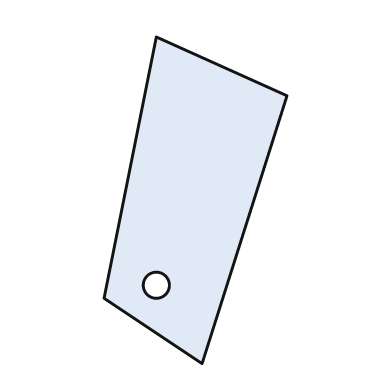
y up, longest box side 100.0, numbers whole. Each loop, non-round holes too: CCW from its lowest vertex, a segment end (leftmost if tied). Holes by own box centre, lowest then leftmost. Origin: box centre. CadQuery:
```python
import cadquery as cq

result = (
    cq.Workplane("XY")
    .moveTo(2.0, -50.0)
    .lineTo(28.0, 32.0)
    .lineTo(-12.0, 50.0)
    .lineTo(-28.0, -30.0)
    .close()
    .moveTo(-12.0, -26.0)
    .circle(4.0)
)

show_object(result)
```